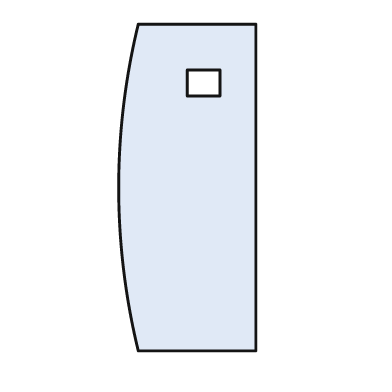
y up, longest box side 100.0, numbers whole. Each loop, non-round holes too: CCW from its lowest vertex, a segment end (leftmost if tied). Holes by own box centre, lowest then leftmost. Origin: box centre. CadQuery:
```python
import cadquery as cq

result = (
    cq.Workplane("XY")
    .moveTo(-15.0, -50.0)
    .lineTo(21.0, -50.0)
    .lineTo(21.0, 50.0)
    .lineTo(-15.0, 50.0)
    .threePointArc((-21.0, 0.0), (-15.0, -50.0))
    .close()
    .moveTo(0.0, 28.0)
    .lineTo(10.0, 28.0)
    .lineTo(10.0, 36.0)
    .lineTo(0.0, 36.0)
    .close()
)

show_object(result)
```